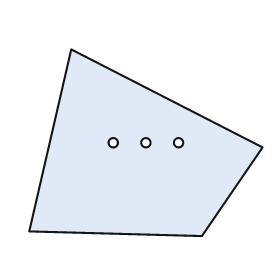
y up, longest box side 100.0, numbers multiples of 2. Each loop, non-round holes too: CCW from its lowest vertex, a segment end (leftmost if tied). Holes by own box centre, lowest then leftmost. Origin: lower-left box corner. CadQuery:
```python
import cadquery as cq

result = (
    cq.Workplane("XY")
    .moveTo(74.0, 0.0)
    .lineTo(100.0, 38.0)
    .lineTo(18.0, 80.0)
    .lineTo(0.0, 2.0)
    .close()
    .moveTo(36.0, 40.0)
    .circle(2.0)
    .moveTo(50.0, 40.0)
    .circle(2.0)
    .moveTo(64.0, 40.0)
    .circle(2.0)
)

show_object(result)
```